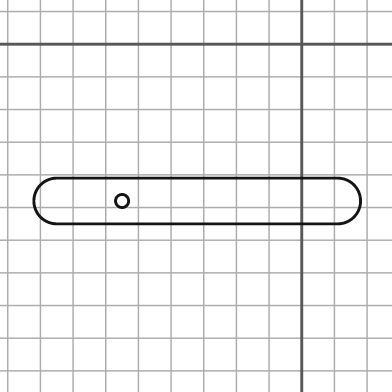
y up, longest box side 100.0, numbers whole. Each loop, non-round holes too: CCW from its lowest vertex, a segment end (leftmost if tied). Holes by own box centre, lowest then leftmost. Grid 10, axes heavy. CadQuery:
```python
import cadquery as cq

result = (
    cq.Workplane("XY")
    .moveTo(-75.0, -55.0)
    .lineTo(11.0, -55.0)
    .threePointArc((18.0, -48.0), (11.0, -41.0))
    .lineTo(-75.0, -41.0)
    .threePointArc((-82.0, -48.0), (-75.0, -55.0))
    .close()
    .moveTo(-55.0, -48.0)
    .circle(2.0)
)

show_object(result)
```